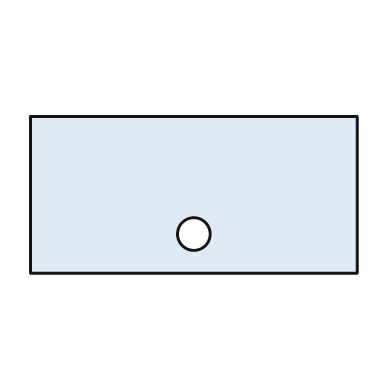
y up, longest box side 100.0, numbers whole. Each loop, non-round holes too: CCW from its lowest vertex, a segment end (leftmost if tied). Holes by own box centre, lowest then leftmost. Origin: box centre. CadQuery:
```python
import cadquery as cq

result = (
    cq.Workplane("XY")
    .moveTo(-50.0, -24.0)
    .lineTo(50.0, -24.0)
    .lineTo(50.0, 24.0)
    .lineTo(-50.0, 24.0)
    .close()
    .moveTo(0.0, -12.0)
    .circle(5.0)
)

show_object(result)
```